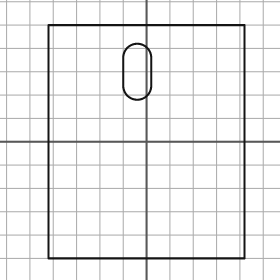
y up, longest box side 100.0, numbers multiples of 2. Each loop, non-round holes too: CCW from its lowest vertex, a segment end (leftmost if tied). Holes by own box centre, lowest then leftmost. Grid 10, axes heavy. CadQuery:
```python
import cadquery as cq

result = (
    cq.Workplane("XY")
    .moveTo(-42.0, -50.0)
    .lineTo(42.0, -50.0)
    .lineTo(42.0, 50.0)
    .lineTo(-42.0, 50.0)
    .close()
    .moveTo(-10.0, 24.0)
    .threePointArc((-4.0, 18.0), (2.0, 24.0))
    .lineTo(2.0, 36.0)
    .threePointArc((-4.0, 42.0), (-10.0, 36.0))
    .close()
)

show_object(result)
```